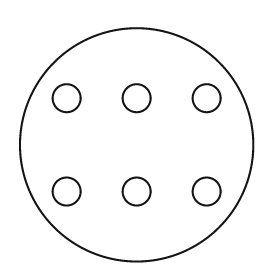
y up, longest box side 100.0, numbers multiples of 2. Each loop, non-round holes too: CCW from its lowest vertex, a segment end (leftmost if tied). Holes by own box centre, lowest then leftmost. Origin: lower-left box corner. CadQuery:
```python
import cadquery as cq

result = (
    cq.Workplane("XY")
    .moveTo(50.0, 50.0)
    .circle(50.0)
    .moveTo(20.0, 30.0)
    .circle(6.0)
    .moveTo(50.0, 30.0)
    .circle(6.0)
    .moveTo(80.0, 30.0)
    .circle(6.0)
    .moveTo(20.0, 70.0)
    .circle(6.0)
    .moveTo(50.0, 70.0)
    .circle(6.0)
    .moveTo(80.0, 70.0)
    .circle(6.0)
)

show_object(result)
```